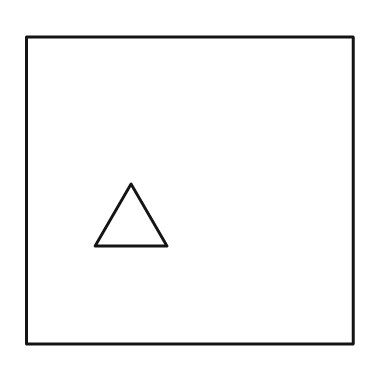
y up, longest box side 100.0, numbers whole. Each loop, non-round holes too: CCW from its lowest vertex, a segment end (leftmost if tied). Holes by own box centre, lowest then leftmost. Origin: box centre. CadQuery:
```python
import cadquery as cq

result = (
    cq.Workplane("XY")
    .moveTo(-50.0, -47.0)
    .lineTo(50.0, -47.0)
    .lineTo(50.0, 47.0)
    .lineTo(-50.0, 47.0)
    .close()
    .moveTo(-29.0, -17.0)
    .lineTo(-7.0, -17.0)
    .lineTo(-18.0, 2.0)
    .close()
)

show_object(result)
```